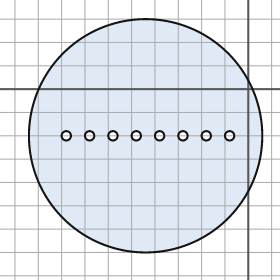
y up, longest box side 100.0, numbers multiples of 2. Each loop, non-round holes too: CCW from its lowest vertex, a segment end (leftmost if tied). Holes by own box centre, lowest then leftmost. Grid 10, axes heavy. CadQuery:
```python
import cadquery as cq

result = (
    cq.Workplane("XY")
    .moveTo(-44.0, -20.0)
    .circle(50.0)
    .moveTo(-78.0, -20.0)
    .circle(2.0)
    .moveTo(-68.0, -20.0)
    .circle(2.0)
    .moveTo(-58.0, -20.0)
    .circle(2.0)
    .moveTo(-48.0, -20.0)
    .circle(2.0)
    .moveTo(-38.0, -20.0)
    .circle(2.0)
    .moveTo(-28.0, -20.0)
    .circle(2.0)
    .moveTo(-18.0, -20.0)
    .circle(2.0)
    .moveTo(-8.0, -20.0)
    .circle(2.0)
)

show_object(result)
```